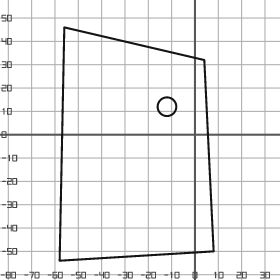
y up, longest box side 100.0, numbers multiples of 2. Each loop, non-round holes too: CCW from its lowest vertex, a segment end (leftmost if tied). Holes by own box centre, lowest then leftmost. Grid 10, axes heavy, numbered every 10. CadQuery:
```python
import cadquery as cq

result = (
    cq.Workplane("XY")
    .moveTo(-58.0, -54.0)
    .lineTo(8.0, -50.0)
    .lineTo(4.0, 32.0)
    .lineTo(-56.0, 46.0)
    .close()
    .moveTo(-12.0, 12.0)
    .circle(4.0)
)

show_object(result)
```